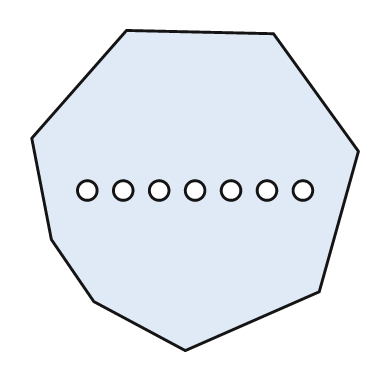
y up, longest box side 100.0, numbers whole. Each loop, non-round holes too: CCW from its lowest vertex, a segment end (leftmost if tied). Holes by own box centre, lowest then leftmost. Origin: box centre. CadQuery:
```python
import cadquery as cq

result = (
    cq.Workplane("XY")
    .moveTo(-3.0, -49.0)
    .lineTo(38.0, -31.0)
    .lineTo(50.0, 12.0)
    .lineTo(24.0, 48.0)
    .lineTo(-21.0, 49.0)
    .lineTo(-50.0, 16.0)
    .lineTo(-44.0, -15.0)
    .lineTo(-31.0, -34.0)
    .close()
    .moveTo(-33.0, 0.0)
    .circle(3.0)
    .moveTo(-22.0, 0.0)
    .circle(3.0)
    .moveTo(-11.0, 0.0)
    .circle(3.0)
    .moveTo(0.0, 0.0)
    .circle(3.0)
    .moveTo(11.0, 0.0)
    .circle(3.0)
    .moveTo(22.0, 0.0)
    .circle(3.0)
    .moveTo(33.0, 0.0)
    .circle(3.0)
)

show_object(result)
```